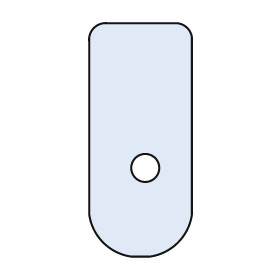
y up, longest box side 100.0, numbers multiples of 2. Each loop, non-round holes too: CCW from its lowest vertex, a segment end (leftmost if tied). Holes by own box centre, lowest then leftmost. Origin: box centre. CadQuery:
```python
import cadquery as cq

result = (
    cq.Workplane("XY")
    .moveTo(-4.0, -50.0)
    .lineTo(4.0, -50.0)
    .threePointArc((16.0, -44.0), (22.0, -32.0))
    .lineTo(22.0, 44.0)
    .threePointArc((20.0, 48.0), (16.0, 50.0))
    .lineTo(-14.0, 50.0)
    .threePointArc((-20.0, 48.0), (-22.0, 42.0))
    .lineTo(-22.0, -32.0)
    .threePointArc((-16.0, -44.0), (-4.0, -50.0))
    .close()
    .moveTo(2.0, -12.0)
    .circle(6.0)
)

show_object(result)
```